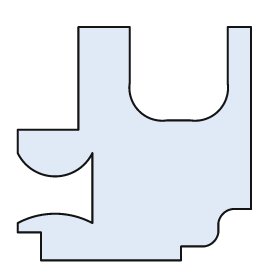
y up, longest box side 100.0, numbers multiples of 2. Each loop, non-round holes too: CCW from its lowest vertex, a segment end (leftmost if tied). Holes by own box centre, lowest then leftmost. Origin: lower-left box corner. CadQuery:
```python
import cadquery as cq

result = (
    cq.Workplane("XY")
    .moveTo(10.0, 0.0)
    .lineTo(70.0, 0.0)
    .lineTo(70.0, 6.0)
    .lineTo(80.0, 6.0)
    .threePointArc((84.0, 8.0), (86.0, 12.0))
    .lineTo(86.0, 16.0)
    .threePointArc((88.0, 20.0), (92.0, 22.0))
    .lineTo(100.0, 22.0)
    .lineTo(100.0, 100.0)
    .lineTo(90.0, 100.0)
    .lineTo(90.0, 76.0)
    .threePointArc((86.0, 64.0), (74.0, 60.0))
    .lineTo(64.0, 60.0)
    .threePointArc((52.0, 64.0), (48.0, 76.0))
    .lineTo(48.0, 100.0)
    .lineTo(26.0, 100.0)
    .lineTo(26.0, 56.0)
    .lineTo(0.0, 56.0)
    .lineTo(0.0, 46.0)
    .threePointArc((16.0, 36.0), (32.0, 46.0))
    .lineTo(32.0, 16.0)
    .threePointArc((16.0, 20.0), (0.0, 16.0))
    .lineTo(0.0, 12.0)
    .lineTo(10.0, 12.0)
    .close()
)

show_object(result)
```